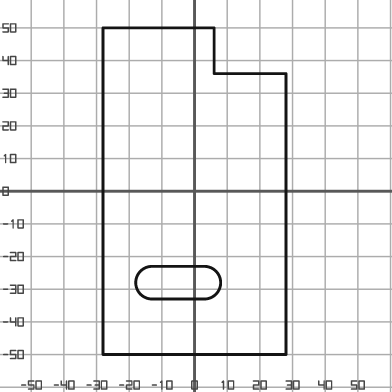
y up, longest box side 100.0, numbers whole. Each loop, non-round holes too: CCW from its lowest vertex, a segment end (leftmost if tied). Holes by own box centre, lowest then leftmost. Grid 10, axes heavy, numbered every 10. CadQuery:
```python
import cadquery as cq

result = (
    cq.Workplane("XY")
    .moveTo(-28.0, -50.0)
    .lineTo(28.0, -50.0)
    .lineTo(28.0, 36.0)
    .lineTo(6.0, 36.0)
    .lineTo(6.0, 50.0)
    .lineTo(-28.0, 50.0)
    .close()
    .moveTo(-13.0, -33.0)
    .lineTo(3.0, -33.0)
    .threePointArc((8.0, -28.0), (3.0, -23.0))
    .lineTo(-13.0, -23.0)
    .threePointArc((-18.0, -28.0), (-13.0, -33.0))
    .close()
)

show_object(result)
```